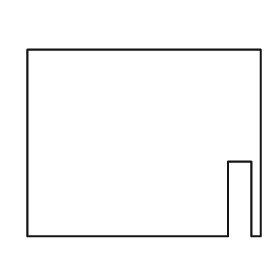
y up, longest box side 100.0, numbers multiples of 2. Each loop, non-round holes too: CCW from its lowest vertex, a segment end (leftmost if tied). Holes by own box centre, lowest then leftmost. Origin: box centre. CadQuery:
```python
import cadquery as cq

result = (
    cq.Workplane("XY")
    .moveTo(-50.0, -40.0)
    .lineTo(36.0, -40.0)
    .lineTo(36.0, -8.0)
    .lineTo(46.0, -8.0)
    .lineTo(46.0, -40.0)
    .lineTo(50.0, -40.0)
    .lineTo(50.0, 40.0)
    .lineTo(-50.0, 40.0)
    .close()
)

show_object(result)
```